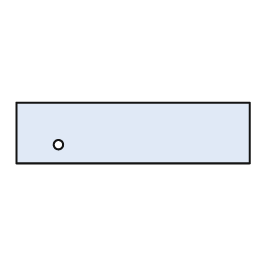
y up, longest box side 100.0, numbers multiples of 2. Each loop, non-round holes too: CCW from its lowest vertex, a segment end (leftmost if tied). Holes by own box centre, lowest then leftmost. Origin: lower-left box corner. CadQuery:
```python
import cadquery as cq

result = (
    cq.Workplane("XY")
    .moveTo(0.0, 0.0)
    .lineTo(100.0, 0.0)
    .lineTo(100.0, 26.0)
    .lineTo(0.0, 26.0)
    .close()
    .moveTo(18.0, 8.0)
    .circle(2.0)
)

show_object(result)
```